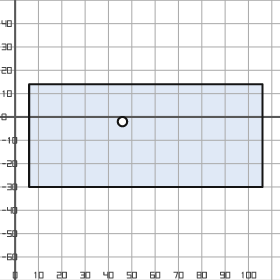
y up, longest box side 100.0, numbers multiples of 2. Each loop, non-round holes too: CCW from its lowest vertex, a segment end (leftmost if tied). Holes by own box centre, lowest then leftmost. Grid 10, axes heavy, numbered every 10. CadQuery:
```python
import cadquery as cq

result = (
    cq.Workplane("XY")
    .moveTo(6.0, -30.0)
    .lineTo(106.0, -30.0)
    .lineTo(106.0, 14.0)
    .lineTo(6.0, 14.0)
    .close()
    .moveTo(46.0, -2.0)
    .circle(2.0)
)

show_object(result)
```